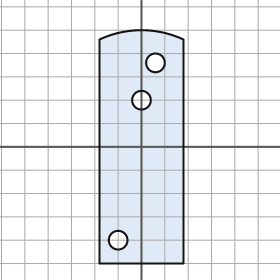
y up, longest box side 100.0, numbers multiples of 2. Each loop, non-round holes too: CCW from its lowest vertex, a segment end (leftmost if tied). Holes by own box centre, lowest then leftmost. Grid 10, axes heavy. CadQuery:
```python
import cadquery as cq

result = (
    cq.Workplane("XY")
    .moveTo(-18.0, -50.0)
    .lineTo(18.0, -50.0)
    .lineTo(18.0, 46.0)
    .threePointArc((0.0, 50.0), (-18.0, 46.0))
    .close()
    .moveTo(-10.0, -40.0)
    .circle(4.0)
    .moveTo(0.0, 20.0)
    .circle(4.0)
    .moveTo(6.0, 36.0)
    .circle(4.0)
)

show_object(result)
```